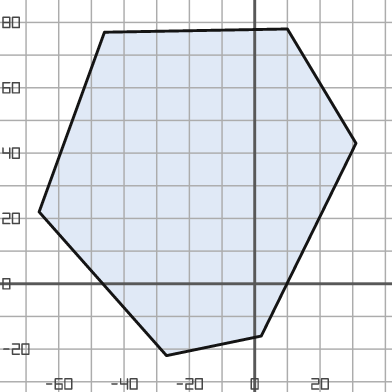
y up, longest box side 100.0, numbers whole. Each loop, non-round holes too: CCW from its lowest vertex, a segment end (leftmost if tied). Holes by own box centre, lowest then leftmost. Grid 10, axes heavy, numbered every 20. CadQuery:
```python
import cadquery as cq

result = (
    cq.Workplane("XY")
    .moveTo(-27.0, -22.0)
    .lineTo(2.0, -16.0)
    .lineTo(31.0, 43.0)
    .lineTo(10.0, 78.0)
    .lineTo(-46.0, 77.0)
    .lineTo(-66.0, 22.0)
    .close()
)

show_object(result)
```